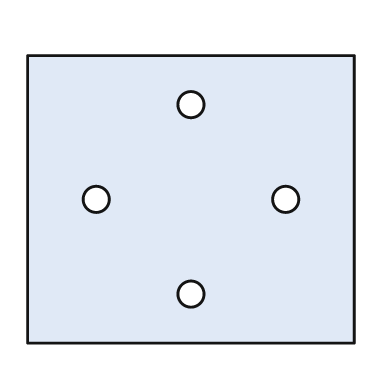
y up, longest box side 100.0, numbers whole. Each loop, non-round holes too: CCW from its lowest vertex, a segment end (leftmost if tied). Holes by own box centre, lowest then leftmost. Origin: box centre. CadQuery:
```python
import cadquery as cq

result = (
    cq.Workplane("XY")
    .moveTo(-50.0, -44.0)
    .lineTo(50.0, -44.0)
    .lineTo(50.0, 44.0)
    .lineTo(-50.0, 44.0)
    .close()
    .moveTo(0.0, -29.0)
    .circle(4.0)
    .moveTo(-29.0, 0.0)
    .circle(4.0)
    .moveTo(29.0, 0.0)
    .circle(4.0)
    .moveTo(0.0, 29.0)
    .circle(4.0)
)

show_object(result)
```